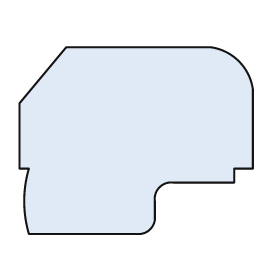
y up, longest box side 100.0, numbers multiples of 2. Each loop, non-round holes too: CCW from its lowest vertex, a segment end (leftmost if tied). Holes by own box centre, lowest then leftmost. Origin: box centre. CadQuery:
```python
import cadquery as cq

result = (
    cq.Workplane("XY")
    .moveTo(-46.0, -40.0)
    .lineTo(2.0, -40.0)
    .threePointArc((6.0, -38.0), (8.0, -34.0))
    .lineTo(8.0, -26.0)
    .threePointArc((10.0, -20.0), (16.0, -18.0))
    .lineTo(42.0, -18.0)
    .lineTo(42.0, -12.0)
    .lineTo(50.0, -12.0)
    .lineTo(50.0, 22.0)
    .threePointArc((44.0, 34.0), (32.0, 40.0))
    .lineTo(-30.0, 40.0)
    .lineTo(-50.0, 16.0)
    .lineTo(-50.0, -12.0)
    .lineTo(-46.0, -12.0)
    .threePointArc((-48.0, -26.0), (-46.0, -40.0))
    .close()
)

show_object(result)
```